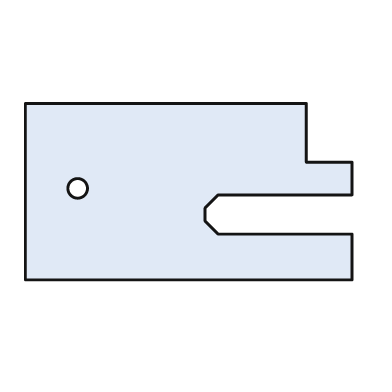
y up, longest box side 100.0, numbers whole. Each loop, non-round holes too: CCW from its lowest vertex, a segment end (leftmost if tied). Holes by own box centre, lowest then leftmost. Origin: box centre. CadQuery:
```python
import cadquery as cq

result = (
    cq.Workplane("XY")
    .moveTo(-50.0, -27.0)
    .lineTo(50.0, -27.0)
    .lineTo(50.0, -13.0)
    .lineTo(9.0, -13.0)
    .lineTo(5.0, -9.0)
    .lineTo(5.0, -5.0)
    .lineTo(9.0, -1.0)
    .lineTo(50.0, -1.0)
    .lineTo(50.0, 9.0)
    .lineTo(36.0, 9.0)
    .lineTo(36.0, 27.0)
    .lineTo(-50.0, 27.0)
    .close()
    .moveTo(-34.0, 1.0)
    .circle(3.0)
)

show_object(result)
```